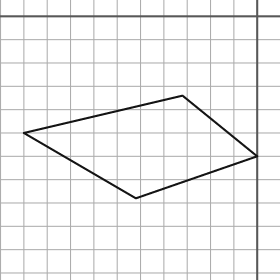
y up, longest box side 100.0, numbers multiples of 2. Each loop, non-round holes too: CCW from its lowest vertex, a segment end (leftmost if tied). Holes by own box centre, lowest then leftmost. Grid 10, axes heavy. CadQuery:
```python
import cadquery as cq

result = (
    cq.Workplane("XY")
    .moveTo(-52.0, -78.0)
    .lineTo(0.0, -60.0)
    .lineTo(-32.0, -34.0)
    .lineTo(-100.0, -50.0)
    .close()
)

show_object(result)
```